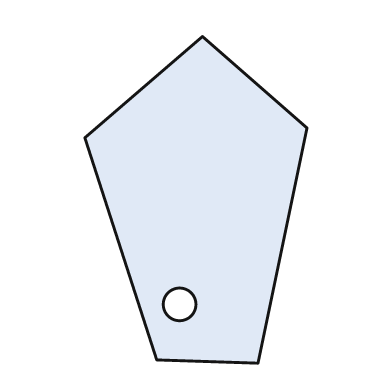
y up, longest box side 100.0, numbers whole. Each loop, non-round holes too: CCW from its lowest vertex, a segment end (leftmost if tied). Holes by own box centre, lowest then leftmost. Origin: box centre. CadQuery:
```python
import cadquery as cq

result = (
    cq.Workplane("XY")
    .moveTo(19.0, -50.0)
    .lineTo(34.0, 22.0)
    .lineTo(2.0, 50.0)
    .lineTo(-34.0, 19.0)
    .lineTo(-12.0, -49.0)
    .close()
    .moveTo(-5.0, -32.0)
    .circle(5.0)
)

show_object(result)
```